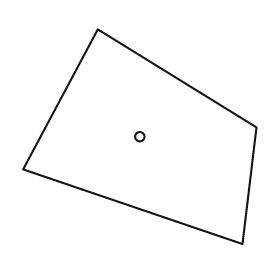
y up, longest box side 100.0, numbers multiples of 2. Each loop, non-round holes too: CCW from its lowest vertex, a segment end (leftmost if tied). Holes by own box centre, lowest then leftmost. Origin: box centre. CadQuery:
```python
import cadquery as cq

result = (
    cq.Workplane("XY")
    .moveTo(44.0, -46.0)
    .lineTo(50.0, 4.0)
    .lineTo(-18.0, 46.0)
    .lineTo(-50.0, -14.0)
    .close()
    .moveTo(0.0, 0.0)
    .circle(2.0)
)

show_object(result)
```